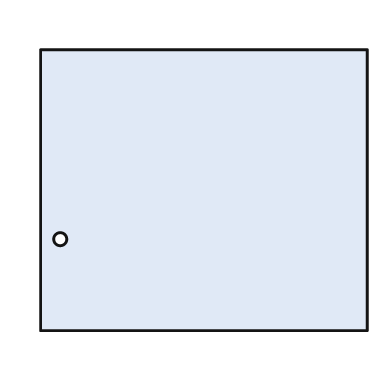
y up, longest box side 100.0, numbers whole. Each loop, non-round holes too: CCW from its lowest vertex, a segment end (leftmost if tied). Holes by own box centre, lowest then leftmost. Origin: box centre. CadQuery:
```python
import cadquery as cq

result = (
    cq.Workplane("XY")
    .moveTo(-50.0, -43.0)
    .lineTo(50.0, -43.0)
    .lineTo(50.0, 43.0)
    .lineTo(-50.0, 43.0)
    .close()
    .moveTo(-44.0, -15.0)
    .circle(2.0)
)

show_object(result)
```